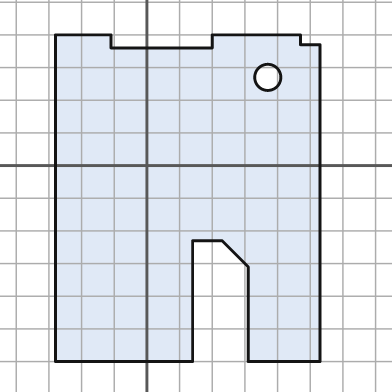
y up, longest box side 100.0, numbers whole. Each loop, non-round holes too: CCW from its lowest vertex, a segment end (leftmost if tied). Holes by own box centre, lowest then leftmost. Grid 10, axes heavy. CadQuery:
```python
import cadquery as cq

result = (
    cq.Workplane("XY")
    .moveTo(-28.0, -60.0)
    .lineTo(14.0, -60.0)
    .lineTo(14.0, -23.0)
    .lineTo(23.0, -23.0)
    .lineTo(31.0, -31.0)
    .lineTo(31.0, -60.0)
    .lineTo(53.0, -60.0)
    .lineTo(53.0, 37.0)
    .lineTo(47.0, 37.0)
    .lineTo(47.0, 40.0)
    .lineTo(20.0, 40.0)
    .lineTo(20.0, 36.0)
    .lineTo(-11.0, 36.0)
    .lineTo(-11.0, 40.0)
    .lineTo(-28.0, 40.0)
    .close()
    .moveTo(37.0, 27.0)
    .circle(4.0)
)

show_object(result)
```